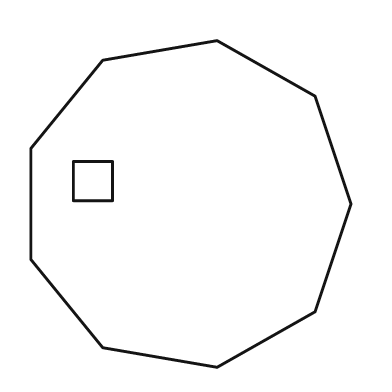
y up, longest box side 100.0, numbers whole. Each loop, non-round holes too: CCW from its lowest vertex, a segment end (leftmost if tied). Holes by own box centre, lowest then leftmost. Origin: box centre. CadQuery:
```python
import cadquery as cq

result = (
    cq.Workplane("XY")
    .moveTo(8.0, -50.0)
    .lineTo(38.0, -33.0)
    .lineTo(49.0, 0.0)
    .lineTo(38.0, 33.0)
    .lineTo(8.0, 50.0)
    .lineTo(-27.0, 44.0)
    .lineTo(-49.0, 17.0)
    .lineTo(-49.0, -17.0)
    .lineTo(-27.0, -44.0)
    .close()
    .moveTo(-36.0, 1.0)
    .lineTo(-24.0, 1.0)
    .lineTo(-24.0, 13.0)
    .lineTo(-36.0, 13.0)
    .close()
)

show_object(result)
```